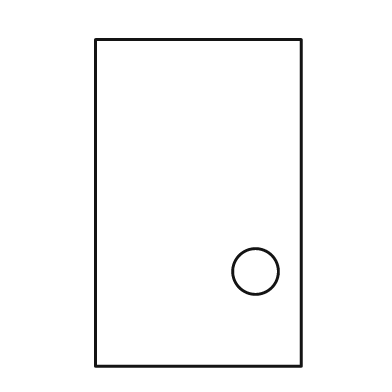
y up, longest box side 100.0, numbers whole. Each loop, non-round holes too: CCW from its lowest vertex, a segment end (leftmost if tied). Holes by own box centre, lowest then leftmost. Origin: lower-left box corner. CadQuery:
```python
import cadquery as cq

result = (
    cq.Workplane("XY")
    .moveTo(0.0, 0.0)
    .lineTo(63.0, 0.0)
    .lineTo(63.0, 100.0)
    .lineTo(0.0, 100.0)
    .close()
    .moveTo(49.0, 29.0)
    .circle(7.0)
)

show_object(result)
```